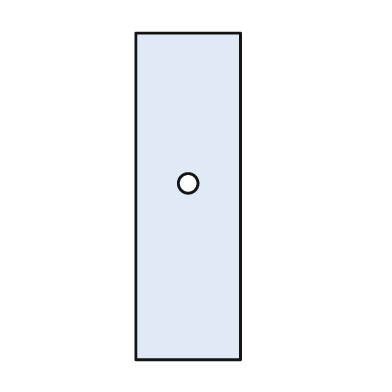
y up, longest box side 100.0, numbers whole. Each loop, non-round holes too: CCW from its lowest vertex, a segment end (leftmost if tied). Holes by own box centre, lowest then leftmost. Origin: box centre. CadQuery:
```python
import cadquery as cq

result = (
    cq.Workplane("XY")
    .moveTo(-16.0, -50.0)
    .lineTo(16.0, -50.0)
    .lineTo(16.0, 50.0)
    .lineTo(-16.0, 50.0)
    .close()
    .moveTo(0.0, 4.0)
    .circle(3.0)
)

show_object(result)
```